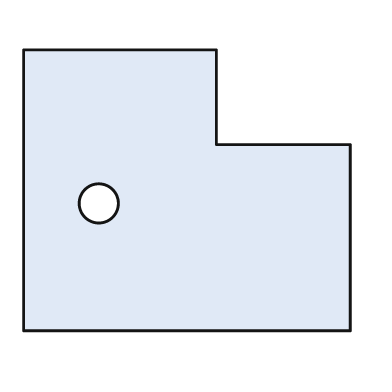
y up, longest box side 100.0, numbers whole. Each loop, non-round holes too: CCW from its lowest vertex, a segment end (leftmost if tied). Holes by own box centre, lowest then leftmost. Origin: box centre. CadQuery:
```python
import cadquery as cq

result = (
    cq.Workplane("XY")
    .moveTo(-50.0, -43.0)
    .lineTo(50.0, -43.0)
    .lineTo(50.0, 14.0)
    .lineTo(9.0, 14.0)
    .lineTo(9.0, 43.0)
    .lineTo(-50.0, 43.0)
    .close()
    .moveTo(-27.0, -4.0)
    .circle(6.0)
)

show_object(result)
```